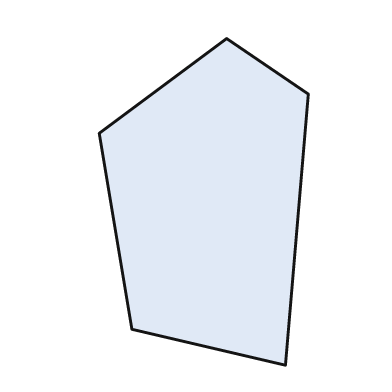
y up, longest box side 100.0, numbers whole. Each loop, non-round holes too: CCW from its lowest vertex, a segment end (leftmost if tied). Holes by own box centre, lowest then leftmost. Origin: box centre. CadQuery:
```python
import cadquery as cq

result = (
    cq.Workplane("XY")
    .moveTo(25.0, -50.0)
    .lineTo(32.0, 33.0)
    .lineTo(7.0, 50.0)
    .lineTo(-32.0, 21.0)
    .lineTo(-22.0, -39.0)
    .close()
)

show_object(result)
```